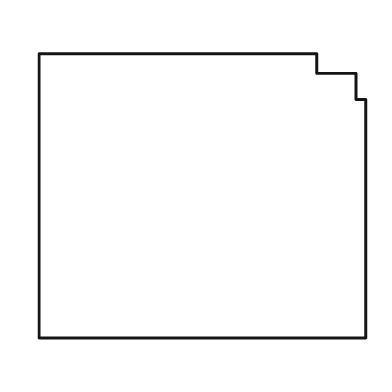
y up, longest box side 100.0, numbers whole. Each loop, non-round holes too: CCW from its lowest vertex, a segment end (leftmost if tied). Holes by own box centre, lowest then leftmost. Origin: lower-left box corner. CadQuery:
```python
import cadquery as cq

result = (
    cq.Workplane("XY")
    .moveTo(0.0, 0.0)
    .lineTo(100.0, 0.0)
    .lineTo(100.0, 73.0)
    .lineTo(97.0, 73.0)
    .lineTo(97.0, 81.0)
    .lineTo(85.0, 81.0)
    .lineTo(85.0, 87.0)
    .lineTo(0.0, 87.0)
    .close()
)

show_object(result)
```